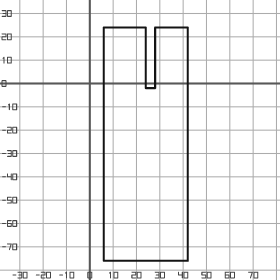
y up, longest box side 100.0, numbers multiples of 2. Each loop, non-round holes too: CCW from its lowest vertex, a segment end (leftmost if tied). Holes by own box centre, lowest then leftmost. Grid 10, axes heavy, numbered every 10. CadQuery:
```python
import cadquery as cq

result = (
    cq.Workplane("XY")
    .moveTo(6.0, -76.0)
    .lineTo(42.0, -76.0)
    .lineTo(42.0, 24.0)
    .lineTo(28.0, 24.0)
    .lineTo(28.0, -2.0)
    .lineTo(24.0, -2.0)
    .lineTo(24.0, 24.0)
    .lineTo(6.0, 24.0)
    .close()
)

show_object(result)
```